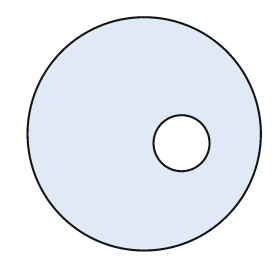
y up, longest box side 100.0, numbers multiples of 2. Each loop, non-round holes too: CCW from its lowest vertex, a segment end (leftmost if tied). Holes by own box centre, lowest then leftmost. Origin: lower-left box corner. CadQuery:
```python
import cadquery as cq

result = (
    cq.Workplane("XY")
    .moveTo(50.0, 50.0)
    .circle(50.0)
    .moveTo(66.0, 46.0)
    .circle(12.0)
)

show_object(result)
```